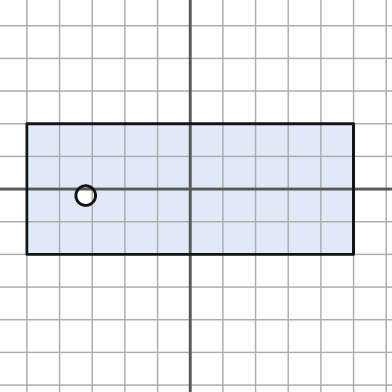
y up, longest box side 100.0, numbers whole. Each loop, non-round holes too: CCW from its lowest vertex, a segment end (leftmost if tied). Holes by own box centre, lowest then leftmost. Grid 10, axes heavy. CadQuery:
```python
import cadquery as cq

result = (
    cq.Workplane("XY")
    .moveTo(-50.0, -20.0)
    .lineTo(50.0, -20.0)
    .lineTo(50.0, 20.0)
    .lineTo(-50.0, 20.0)
    .close()
    .moveTo(-32.0, -2.0)
    .circle(3.0)
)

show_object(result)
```